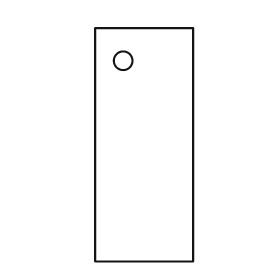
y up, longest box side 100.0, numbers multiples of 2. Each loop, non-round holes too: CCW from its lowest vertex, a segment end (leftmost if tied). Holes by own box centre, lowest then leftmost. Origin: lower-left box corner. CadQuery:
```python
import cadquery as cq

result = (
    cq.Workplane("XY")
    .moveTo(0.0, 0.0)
    .lineTo(42.0, 0.0)
    .lineTo(42.0, 100.0)
    .lineTo(0.0, 100.0)
    .close()
    .moveTo(12.0, 86.0)
    .circle(4.0)
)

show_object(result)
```